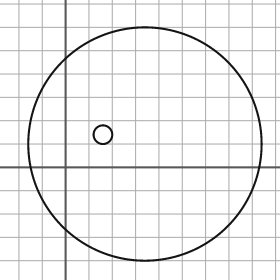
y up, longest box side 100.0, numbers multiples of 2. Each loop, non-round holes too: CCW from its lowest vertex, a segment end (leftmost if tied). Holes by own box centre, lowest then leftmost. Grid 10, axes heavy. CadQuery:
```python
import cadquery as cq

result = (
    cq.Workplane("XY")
    .moveTo(34.0, 10.0)
    .circle(50.0)
    .moveTo(16.0, 14.0)
    .circle(4.0)
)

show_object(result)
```